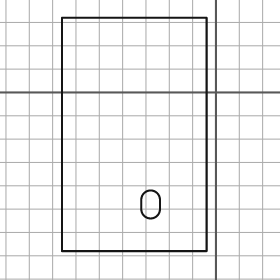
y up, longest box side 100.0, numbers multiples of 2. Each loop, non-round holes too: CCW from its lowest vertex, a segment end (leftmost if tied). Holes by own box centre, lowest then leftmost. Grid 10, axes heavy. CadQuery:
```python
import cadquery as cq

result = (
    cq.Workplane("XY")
    .moveTo(-66.0, -68.0)
    .lineTo(-4.0, -68.0)
    .lineTo(-4.0, 32.0)
    .lineTo(-66.0, 32.0)
    .close()
    .moveTo(-32.0, -50.0)
    .threePointArc((-28.0, -54.0), (-24.0, -50.0))
    .lineTo(-24.0, -46.0)
    .threePointArc((-28.0, -42.0), (-32.0, -46.0))
    .close()
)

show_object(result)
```